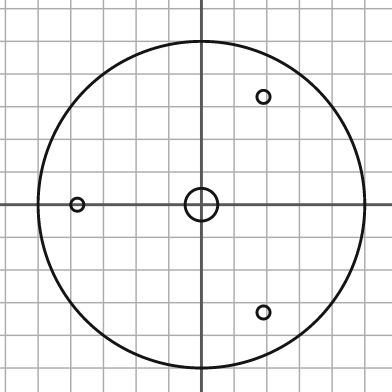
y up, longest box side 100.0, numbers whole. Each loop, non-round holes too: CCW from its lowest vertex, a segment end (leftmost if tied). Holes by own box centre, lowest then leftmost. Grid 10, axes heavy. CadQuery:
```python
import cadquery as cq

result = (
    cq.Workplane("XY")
    .moveTo(0.0, 0.0)
    .circle(50.0)
    .moveTo(19.0, -33.0)
    .circle(2.0)
    .moveTo(-38.0, 0.0)
    .circle(2.0)
    .moveTo(0.0, 0.0)
    .circle(5.0)
    .moveTo(19.0, 33.0)
    .circle(2.0)
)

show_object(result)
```